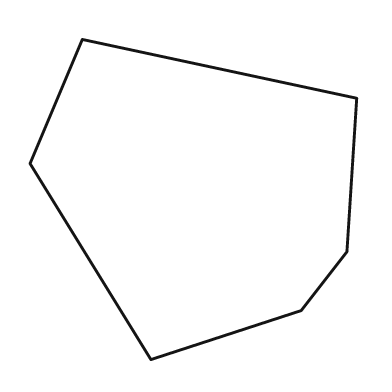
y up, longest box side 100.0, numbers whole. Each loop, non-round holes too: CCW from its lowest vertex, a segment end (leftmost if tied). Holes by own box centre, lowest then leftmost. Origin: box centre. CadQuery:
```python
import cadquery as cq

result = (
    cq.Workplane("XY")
    .moveTo(-13.0, -49.0)
    .lineTo(33.0, -34.0)
    .lineTo(47.0, -16.0)
    .lineTo(50.0, 31.0)
    .lineTo(-34.0, 49.0)
    .lineTo(-50.0, 11.0)
    .close()
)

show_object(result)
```